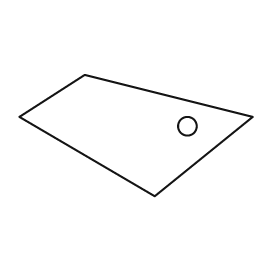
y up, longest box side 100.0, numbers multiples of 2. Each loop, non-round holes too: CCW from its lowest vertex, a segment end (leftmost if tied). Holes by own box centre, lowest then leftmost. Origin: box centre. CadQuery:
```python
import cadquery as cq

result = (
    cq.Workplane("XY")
    .moveTo(8.0, -26.0)
    .lineTo(50.0, 8.0)
    .lineTo(-22.0, 26.0)
    .lineTo(-50.0, 8.0)
    .close()
    .moveTo(22.0, 4.0)
    .circle(4.0)
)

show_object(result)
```